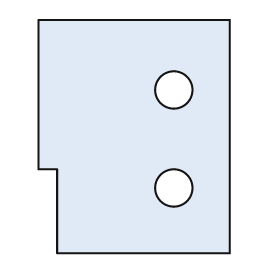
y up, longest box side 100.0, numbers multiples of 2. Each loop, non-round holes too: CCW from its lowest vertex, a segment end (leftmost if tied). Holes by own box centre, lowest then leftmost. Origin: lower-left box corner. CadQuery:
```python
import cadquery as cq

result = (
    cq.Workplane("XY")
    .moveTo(8.0, 0.0)
    .lineTo(82.0, 0.0)
    .lineTo(82.0, 100.0)
    .lineTo(0.0, 100.0)
    .lineTo(0.0, 36.0)
    .lineTo(8.0, 36.0)
    .close()
    .moveTo(58.0, 28.0)
    .circle(8.0)
    .moveTo(58.0, 70.0)
    .circle(8.0)
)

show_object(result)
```